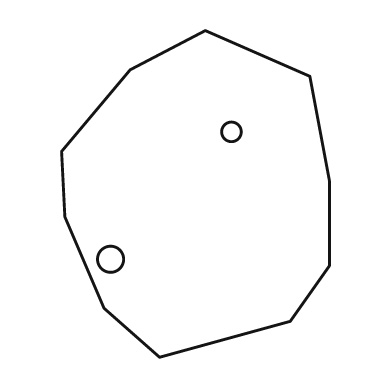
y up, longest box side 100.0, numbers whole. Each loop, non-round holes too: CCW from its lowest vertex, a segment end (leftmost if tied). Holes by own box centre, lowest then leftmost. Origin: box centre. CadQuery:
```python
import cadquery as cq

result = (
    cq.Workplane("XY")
    .moveTo(-11.0, -50.0)
    .lineTo(29.0, -39.0)
    .lineTo(41.0, -22.0)
    .lineTo(41.0, 4.0)
    .lineTo(35.0, 36.0)
    .lineTo(3.0, 50.0)
    .lineTo(-20.0, 38.0)
    .lineTo(-41.0, 13.0)
    .lineTo(-40.0, -7.0)
    .lineTo(-28.0, -35.0)
    .close()
    .moveTo(-26.0, -20.0)
    .circle(4.0)
    .moveTo(11.0, 19.0)
    .circle(3.0)
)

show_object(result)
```